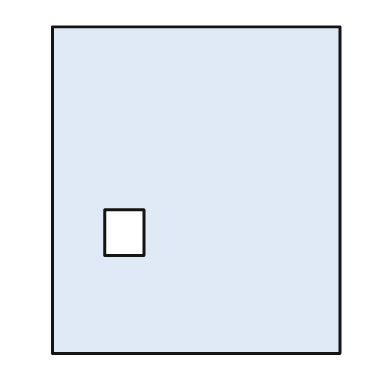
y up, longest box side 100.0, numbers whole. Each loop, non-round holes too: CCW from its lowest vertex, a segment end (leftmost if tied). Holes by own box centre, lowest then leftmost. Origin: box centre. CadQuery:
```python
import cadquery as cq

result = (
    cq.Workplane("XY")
    .moveTo(-44.0, -50.0)
    .lineTo(44.0, -50.0)
    .lineTo(44.0, 50.0)
    .lineTo(-44.0, 50.0)
    .close()
    .moveTo(-28.0, -20.0)
    .lineTo(-16.0, -20.0)
    .lineTo(-16.0, -6.0)
    .lineTo(-28.0, -6.0)
    .close()
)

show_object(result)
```